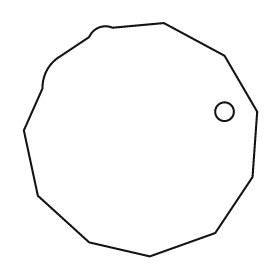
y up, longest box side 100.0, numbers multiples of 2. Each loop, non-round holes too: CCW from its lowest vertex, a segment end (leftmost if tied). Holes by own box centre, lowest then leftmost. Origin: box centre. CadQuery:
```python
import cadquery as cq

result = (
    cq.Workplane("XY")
    .moveTo(4.0, -50.0)
    .lineTo(32.0, -40.0)
    .lineTo(48.0, -16.0)
    .lineTo(50.0, 12.0)
    .lineTo(36.0, 36.0)
    .lineTo(10.0, 50.0)
    .lineTo(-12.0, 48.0)
    .threePointArc((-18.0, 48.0), (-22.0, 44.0))
    .lineTo(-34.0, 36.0)
    .threePointArc((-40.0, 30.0), (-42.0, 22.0))
    .lineTo(-50.0, 4.0)
    .lineTo(-44.0, -24.0)
    .lineTo(-22.0, -44.0)
    .close()
    .moveTo(36.0, 12.0)
    .circle(4.0)
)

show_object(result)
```